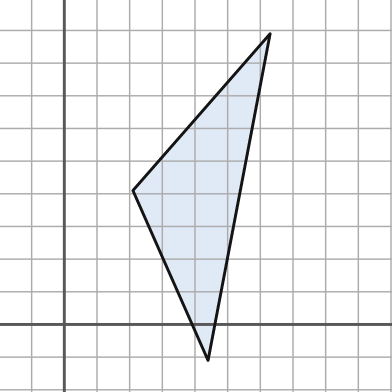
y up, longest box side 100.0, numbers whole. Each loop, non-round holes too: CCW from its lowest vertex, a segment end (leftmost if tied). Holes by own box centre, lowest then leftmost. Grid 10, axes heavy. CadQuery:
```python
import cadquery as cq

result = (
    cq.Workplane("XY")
    .moveTo(44.0, -11.0)
    .lineTo(63.0, 89.0)
    .lineTo(21.0, 41.0)
    .close()
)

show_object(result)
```